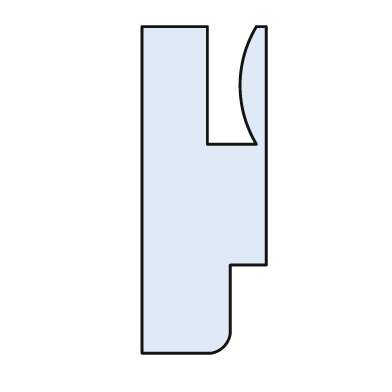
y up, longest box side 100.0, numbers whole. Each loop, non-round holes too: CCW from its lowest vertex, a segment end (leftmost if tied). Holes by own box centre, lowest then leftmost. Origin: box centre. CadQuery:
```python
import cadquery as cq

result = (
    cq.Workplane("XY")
    .moveTo(-19.0, -50.0)
    .lineTo(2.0, -50.0)
    .threePointArc((6.0, -48.0), (8.0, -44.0))
    .lineTo(8.0, -23.0)
    .lineTo(19.0, -23.0)
    .lineTo(19.0, 50.0)
    .lineTo(16.0, 50.0)
    .threePointArc((11.0, 32.0), (16.0, 14.0))
    .lineTo(1.0, 14.0)
    .lineTo(1.0, 50.0)
    .lineTo(-19.0, 50.0)
    .close()
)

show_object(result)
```